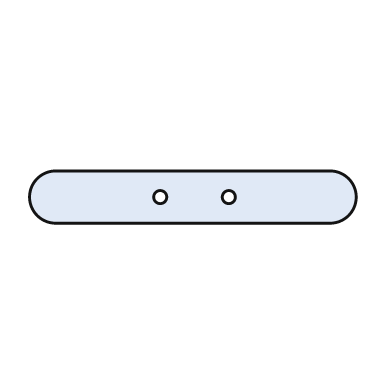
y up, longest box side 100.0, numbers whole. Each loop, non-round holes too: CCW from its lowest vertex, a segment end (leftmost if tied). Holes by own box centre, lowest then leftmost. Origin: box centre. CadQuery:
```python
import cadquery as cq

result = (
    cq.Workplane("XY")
    .moveTo(-42.0, -8.0)
    .lineTo(42.0, -8.0)
    .threePointArc((50.0, 0.0), (42.0, 8.0))
    .lineTo(-42.0, 8.0)
    .threePointArc((-50.0, 0.0), (-42.0, -8.0))
    .close()
    .moveTo(-10.0, 0.0)
    .circle(2.0)
    .moveTo(11.0, 0.0)
    .circle(2.0)
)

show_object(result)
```